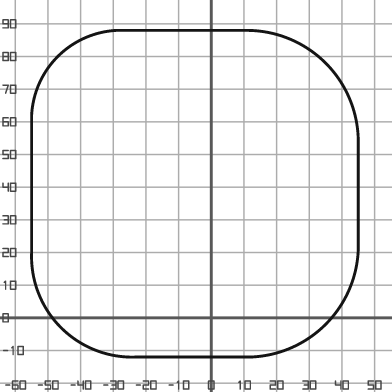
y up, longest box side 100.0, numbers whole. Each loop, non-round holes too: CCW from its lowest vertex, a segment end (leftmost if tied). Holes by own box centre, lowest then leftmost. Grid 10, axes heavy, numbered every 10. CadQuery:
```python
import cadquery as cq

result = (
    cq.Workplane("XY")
    .moveTo(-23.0, -12.0)
    .lineTo(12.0, -12.0)
    .threePointArc((35.0, -2.0), (45.0, 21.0))
    .lineTo(45.0, 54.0)
    .threePointArc((35.0, 78.0), (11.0, 88.0))
    .lineTo(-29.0, 88.0)
    .threePointArc((-47.0, 80.0), (-55.0, 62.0))
    .lineTo(-55.0, 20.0)
    .threePointArc((-46.0, -3.0), (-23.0, -12.0))
    .close()
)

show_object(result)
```